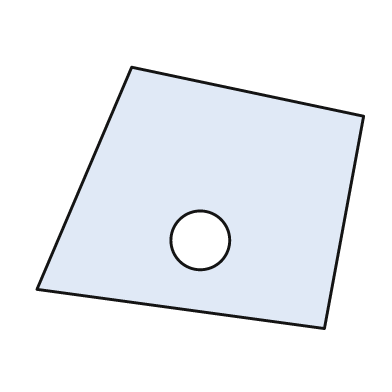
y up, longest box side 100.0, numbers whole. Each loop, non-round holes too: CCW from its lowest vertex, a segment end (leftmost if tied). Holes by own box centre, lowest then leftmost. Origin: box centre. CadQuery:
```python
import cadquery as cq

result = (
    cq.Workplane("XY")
    .moveTo(38.0, -40.0)
    .lineTo(50.0, 25.0)
    .lineTo(-21.0, 40.0)
    .lineTo(-50.0, -28.0)
    .close()
    .moveTo(0.0, -13.0)
    .circle(9.0)
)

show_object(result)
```